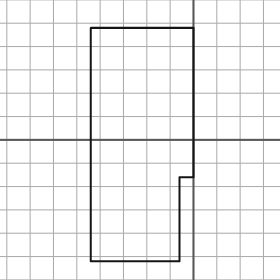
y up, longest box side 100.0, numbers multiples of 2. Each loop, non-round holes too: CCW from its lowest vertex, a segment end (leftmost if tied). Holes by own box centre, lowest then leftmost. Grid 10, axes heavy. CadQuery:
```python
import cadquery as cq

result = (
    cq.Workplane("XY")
    .moveTo(-44.0, -52.0)
    .lineTo(-6.0, -52.0)
    .lineTo(-6.0, -16.0)
    .lineTo(0.0, -16.0)
    .lineTo(0.0, 48.0)
    .lineTo(-44.0, 48.0)
    .close()
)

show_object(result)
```